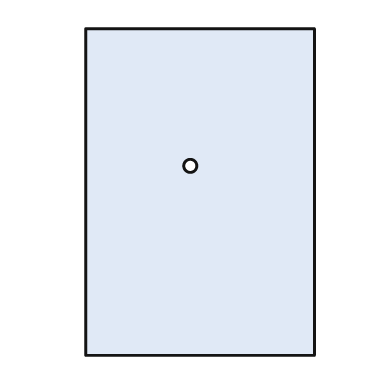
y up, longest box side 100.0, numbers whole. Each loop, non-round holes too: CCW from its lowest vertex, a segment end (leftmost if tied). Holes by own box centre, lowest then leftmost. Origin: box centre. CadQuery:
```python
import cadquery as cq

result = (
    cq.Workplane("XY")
    .moveTo(-35.0, -50.0)
    .lineTo(35.0, -50.0)
    .lineTo(35.0, 50.0)
    .lineTo(-35.0, 50.0)
    .close()
    .moveTo(-3.0, 8.0)
    .circle(2.0)
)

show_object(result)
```